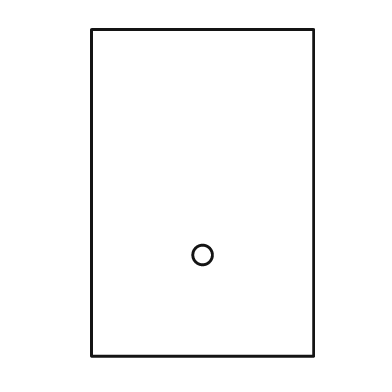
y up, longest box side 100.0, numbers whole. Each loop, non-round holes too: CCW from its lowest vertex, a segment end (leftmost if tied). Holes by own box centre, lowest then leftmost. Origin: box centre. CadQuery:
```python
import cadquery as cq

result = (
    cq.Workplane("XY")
    .moveTo(-34.0, -50.0)
    .lineTo(34.0, -50.0)
    .lineTo(34.0, 50.0)
    .lineTo(-34.0, 50.0)
    .close()
    .moveTo(0.0, -19.0)
    .circle(3.0)
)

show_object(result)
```